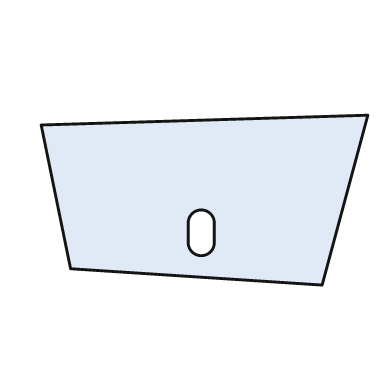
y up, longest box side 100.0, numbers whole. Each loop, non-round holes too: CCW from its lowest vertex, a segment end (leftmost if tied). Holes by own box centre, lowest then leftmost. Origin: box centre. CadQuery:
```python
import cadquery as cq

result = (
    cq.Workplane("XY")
    .moveTo(36.0, -26.0)
    .lineTo(50.0, 26.0)
    .lineTo(-50.0, 23.0)
    .lineTo(-41.0, -21.0)
    .close()
    .moveTo(-5.0, -13.0)
    .threePointArc((-1.0, -17.0), (3.0, -13.0))
    .lineTo(3.0, -7.0)
    .threePointArc((-1.0, -3.0), (-5.0, -7.0))
    .close()
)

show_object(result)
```